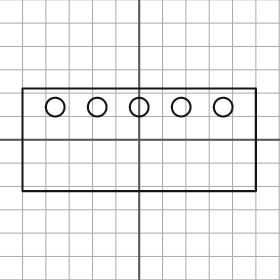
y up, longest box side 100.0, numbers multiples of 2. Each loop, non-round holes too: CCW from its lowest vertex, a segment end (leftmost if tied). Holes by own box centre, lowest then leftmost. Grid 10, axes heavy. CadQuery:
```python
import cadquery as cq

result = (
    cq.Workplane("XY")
    .moveTo(-50.0, -22.0)
    .lineTo(50.0, -22.0)
    .lineTo(50.0, 22.0)
    .lineTo(-50.0, 22.0)
    .close()
    .moveTo(-36.0, 14.0)
    .circle(4.0)
    .moveTo(-18.0, 14.0)
    .circle(4.0)
    .moveTo(0.0, 14.0)
    .circle(4.0)
    .moveTo(18.0, 14.0)
    .circle(4.0)
    .moveTo(36.0, 14.0)
    .circle(4.0)
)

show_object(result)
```